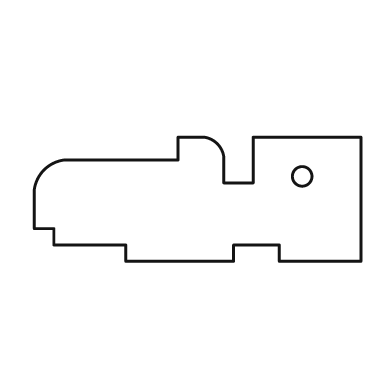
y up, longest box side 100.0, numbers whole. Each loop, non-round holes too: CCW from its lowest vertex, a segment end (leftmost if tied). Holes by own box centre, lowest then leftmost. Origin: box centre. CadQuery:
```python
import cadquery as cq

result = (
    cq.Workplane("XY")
    .moveTo(-22.0, -19.0)
    .lineTo(11.0, -19.0)
    .lineTo(11.0, -14.0)
    .lineTo(25.0, -14.0)
    .lineTo(25.0, -19.0)
    .lineTo(50.0, -19.0)
    .lineTo(50.0, 19.0)
    .lineTo(17.0, 19.0)
    .lineTo(17.0, 5.0)
    .lineTo(8.0, 5.0)
    .lineTo(8.0, 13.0)
    .threePointArc((6.0, 17.0), (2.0, 19.0))
    .lineTo(-6.0, 19.0)
    .lineTo(-6.0, 12.0)
    .lineTo(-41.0, 12.0)
    .threePointArc((-47.0, 9.0), (-50.0, 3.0))
    .lineTo(-50.0, -9.0)
    .lineTo(-44.0, -9.0)
    .lineTo(-44.0, -14.0)
    .lineTo(-22.0, -14.0)
    .close()
    .moveTo(32.0, 7.0)
    .circle(3.0)
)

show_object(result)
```